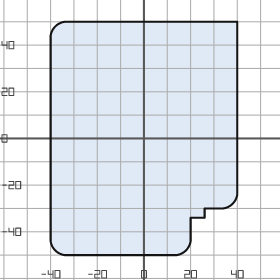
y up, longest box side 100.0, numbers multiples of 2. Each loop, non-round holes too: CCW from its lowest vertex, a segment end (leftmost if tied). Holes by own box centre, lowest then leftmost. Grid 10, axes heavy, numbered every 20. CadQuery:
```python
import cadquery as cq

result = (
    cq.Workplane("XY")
    .moveTo(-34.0, -50.0)
    .lineTo(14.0, -50.0)
    .threePointArc((18.0, -48.0), (20.0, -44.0))
    .lineTo(20.0, -34.0)
    .lineTo(26.0, -34.0)
    .lineTo(26.0, -30.0)
    .lineTo(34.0, -30.0)
    .threePointArc((38.0, -28.0), (40.0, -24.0))
    .lineTo(40.0, 50.0)
    .lineTo(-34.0, 50.0)
    .threePointArc((-38.0, 48.0), (-40.0, 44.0))
    .lineTo(-40.0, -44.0)
    .threePointArc((-38.0, -48.0), (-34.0, -50.0))
    .close()
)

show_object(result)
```